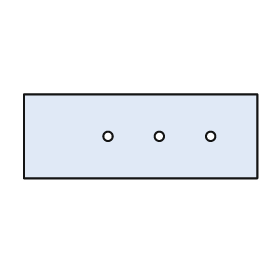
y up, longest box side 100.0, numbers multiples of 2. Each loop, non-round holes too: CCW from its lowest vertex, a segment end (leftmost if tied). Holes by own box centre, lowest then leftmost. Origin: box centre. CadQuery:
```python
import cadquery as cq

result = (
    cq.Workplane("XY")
    .moveTo(-50.0, -18.0)
    .lineTo(50.0, -18.0)
    .lineTo(50.0, 18.0)
    .lineTo(-50.0, 18.0)
    .close()
    .moveTo(-14.0, 0.0)
    .circle(2.0)
    .moveTo(8.0, 0.0)
    .circle(2.0)
    .moveTo(30.0, 0.0)
    .circle(2.0)
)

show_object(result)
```